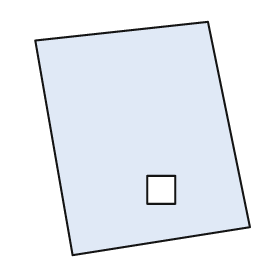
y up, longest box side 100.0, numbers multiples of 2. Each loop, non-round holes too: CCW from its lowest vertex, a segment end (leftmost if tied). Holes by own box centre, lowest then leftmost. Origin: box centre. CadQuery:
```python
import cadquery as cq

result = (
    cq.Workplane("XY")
    .moveTo(-30.0, -50.0)
    .lineTo(46.0, -38.0)
    .lineTo(28.0, 50.0)
    .lineTo(-46.0, 42.0)
    .close()
    .moveTo(2.0, -28.0)
    .lineTo(14.0, -28.0)
    .lineTo(14.0, -16.0)
    .lineTo(2.0, -16.0)
    .close()
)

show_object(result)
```